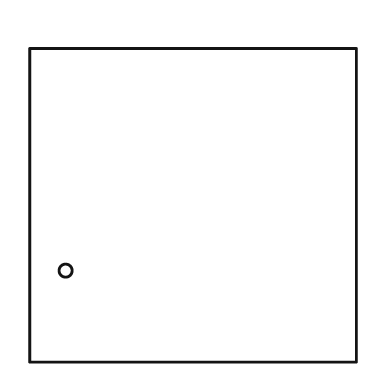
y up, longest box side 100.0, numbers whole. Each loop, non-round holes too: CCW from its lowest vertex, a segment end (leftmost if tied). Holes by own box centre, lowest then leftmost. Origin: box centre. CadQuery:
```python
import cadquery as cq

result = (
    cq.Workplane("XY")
    .moveTo(-50.0, -48.0)
    .lineTo(50.0, -48.0)
    .lineTo(50.0, 48.0)
    .lineTo(-50.0, 48.0)
    .close()
    .moveTo(-39.0, -20.0)
    .circle(2.0)
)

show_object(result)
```